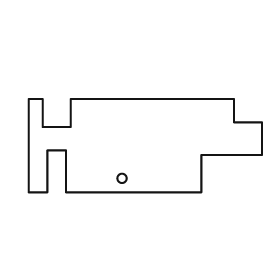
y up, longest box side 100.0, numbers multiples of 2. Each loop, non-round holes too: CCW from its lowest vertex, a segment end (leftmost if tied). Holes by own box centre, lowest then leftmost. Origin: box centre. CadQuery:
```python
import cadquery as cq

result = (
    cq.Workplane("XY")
    .moveTo(-50.0, -20.0)
    .lineTo(-42.0, -20.0)
    .lineTo(-42.0, -2.0)
    .lineTo(-34.0, -2.0)
    .lineTo(-34.0, -20.0)
    .lineTo(24.0, -20.0)
    .lineTo(24.0, -4.0)
    .lineTo(50.0, -4.0)
    .lineTo(50.0, 10.0)
    .lineTo(38.0, 10.0)
    .lineTo(38.0, 20.0)
    .lineTo(-32.0, 20.0)
    .lineTo(-32.0, 8.0)
    .lineTo(-44.0, 8.0)
    .lineTo(-44.0, 20.0)
    .lineTo(-50.0, 20.0)
    .close()
    .moveTo(-10.0, -14.0)
    .circle(2.0)
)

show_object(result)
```